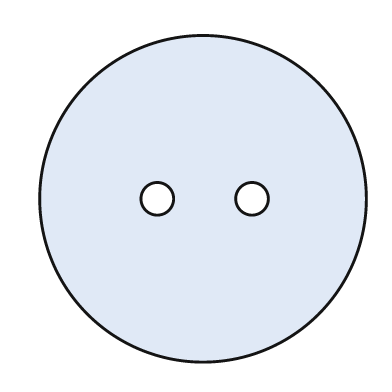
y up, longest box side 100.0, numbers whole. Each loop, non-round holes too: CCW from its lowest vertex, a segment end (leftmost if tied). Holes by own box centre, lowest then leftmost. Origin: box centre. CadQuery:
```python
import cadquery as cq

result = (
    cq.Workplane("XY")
    .moveTo(0.0, 0.0)
    .circle(50.0)
    .moveTo(-14.0, 0.0)
    .circle(5.0)
    .moveTo(15.0, 0.0)
    .circle(5.0)
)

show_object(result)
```